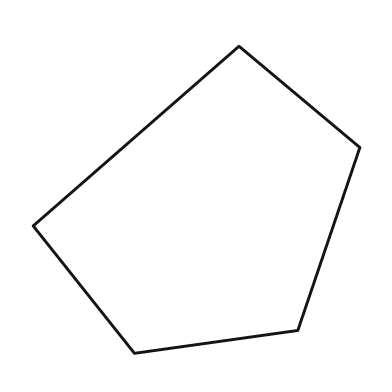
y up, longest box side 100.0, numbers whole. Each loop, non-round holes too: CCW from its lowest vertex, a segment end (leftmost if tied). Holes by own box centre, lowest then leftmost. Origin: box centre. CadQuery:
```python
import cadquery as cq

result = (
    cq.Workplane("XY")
    .moveTo(-19.0, -47.0)
    .lineTo(31.0, -40.0)
    .lineTo(50.0, 16.0)
    .lineTo(13.0, 47.0)
    .lineTo(-50.0, -8.0)
    .close()
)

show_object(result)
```